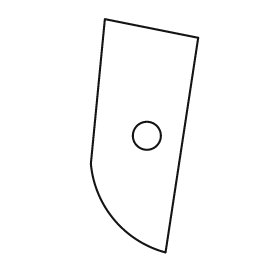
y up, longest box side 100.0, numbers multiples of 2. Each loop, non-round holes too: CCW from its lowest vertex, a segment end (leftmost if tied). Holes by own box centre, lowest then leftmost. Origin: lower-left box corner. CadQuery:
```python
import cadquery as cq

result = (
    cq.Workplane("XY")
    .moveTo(32.0, 0.0)
    .lineTo(46.0, 92.0)
    .lineTo(6.0, 100.0)
    .lineTo(0.0, 38.0)
    .threePointArc((10.0, 14.0), (32.0, 0.0))
    .close()
    .moveTo(24.0, 50.0)
    .circle(6.0)
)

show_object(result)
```